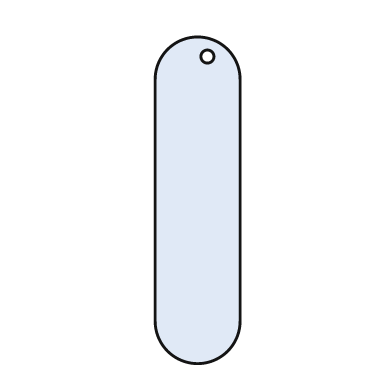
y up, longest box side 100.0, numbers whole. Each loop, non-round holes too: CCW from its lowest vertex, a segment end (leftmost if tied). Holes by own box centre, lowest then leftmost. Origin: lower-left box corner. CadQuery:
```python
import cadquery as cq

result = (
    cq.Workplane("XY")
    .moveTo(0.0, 13.0)
    .threePointArc((13.0, 0.0), (26.0, 13.0))
    .lineTo(26.0, 87.0)
    .threePointArc((13.0, 100.0), (0.0, 87.0))
    .close()
    .moveTo(16.0, 94.0)
    .circle(2.0)
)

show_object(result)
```